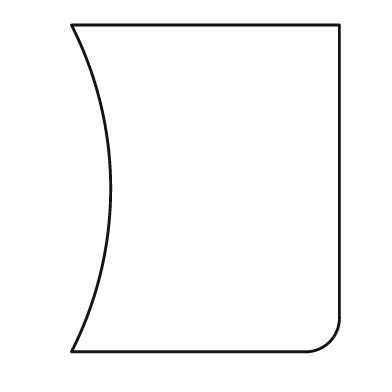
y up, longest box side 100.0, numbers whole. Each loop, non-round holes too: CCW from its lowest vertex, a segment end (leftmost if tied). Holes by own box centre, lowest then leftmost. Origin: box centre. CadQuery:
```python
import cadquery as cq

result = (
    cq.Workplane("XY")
    .moveTo(-41.0, -50.0)
    .lineTo(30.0, -50.0)
    .threePointArc((38.0, -47.0), (41.0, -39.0))
    .lineTo(41.0, 50.0)
    .lineTo(-41.0, 50.0)
    .threePointArc((-29.0, 0.0), (-41.0, -50.0))
    .close()
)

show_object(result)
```